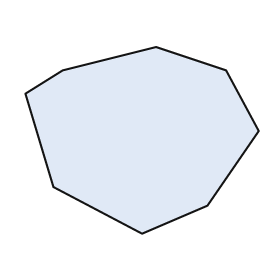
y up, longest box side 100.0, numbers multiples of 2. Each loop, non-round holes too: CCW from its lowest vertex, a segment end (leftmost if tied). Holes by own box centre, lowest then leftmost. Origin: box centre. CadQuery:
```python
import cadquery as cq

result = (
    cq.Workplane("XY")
    .moveTo(0.0, -40.0)
    .lineTo(28.0, -28.0)
    .lineTo(50.0, 4.0)
    .lineTo(36.0, 30.0)
    .lineTo(6.0, 40.0)
    .lineTo(-34.0, 30.0)
    .lineTo(-50.0, 20.0)
    .lineTo(-38.0, -20.0)
    .close()
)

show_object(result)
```